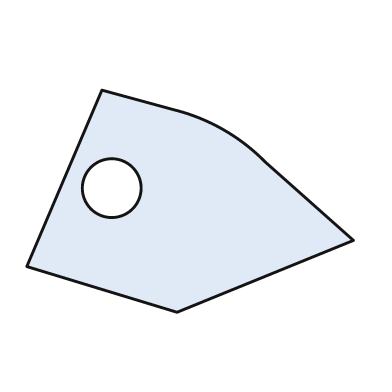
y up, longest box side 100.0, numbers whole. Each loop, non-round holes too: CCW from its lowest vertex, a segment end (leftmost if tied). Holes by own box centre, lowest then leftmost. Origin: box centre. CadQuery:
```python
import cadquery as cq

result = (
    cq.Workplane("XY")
    .moveTo(-4.0, -34.0)
    .lineTo(50.0, -12.0)
    .lineTo(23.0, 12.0)
    .threePointArc((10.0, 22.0), (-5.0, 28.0))
    .lineTo(-27.0, 34.0)
    .lineTo(-50.0, -20.0)
    .close()
    .moveTo(-24.0, 4.0)
    .circle(9.0)
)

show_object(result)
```